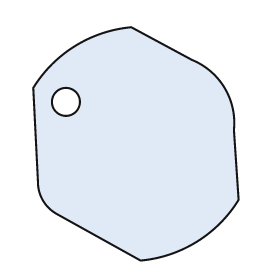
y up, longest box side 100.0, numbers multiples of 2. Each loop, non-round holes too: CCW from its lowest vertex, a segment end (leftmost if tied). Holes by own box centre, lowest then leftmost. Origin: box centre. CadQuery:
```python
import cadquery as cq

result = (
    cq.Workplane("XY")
    .moveTo(2.0, -50.0)
    .threePointArc((26.0, -42.0), (44.0, -24.0))
    .lineTo(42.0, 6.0)
    .threePointArc((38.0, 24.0), (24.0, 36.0))
    .lineTo(-2.0, 50.0)
    .threePointArc((-26.0, 42.0), (-44.0, 24.0))
    .lineTo(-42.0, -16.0)
    .threePointArc((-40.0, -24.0), (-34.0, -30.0))
    .close()
    .moveTo(-30.0, 18.0)
    .circle(6.0)
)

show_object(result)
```